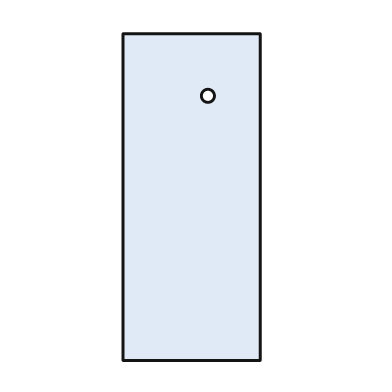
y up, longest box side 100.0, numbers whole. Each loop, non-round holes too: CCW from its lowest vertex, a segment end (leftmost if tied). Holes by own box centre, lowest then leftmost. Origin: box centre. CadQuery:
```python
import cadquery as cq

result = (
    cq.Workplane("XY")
    .moveTo(-21.0, -50.0)
    .lineTo(21.0, -50.0)
    .lineTo(21.0, 50.0)
    .lineTo(-21.0, 50.0)
    .close()
    .moveTo(5.0, 31.0)
    .circle(2.0)
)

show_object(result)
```